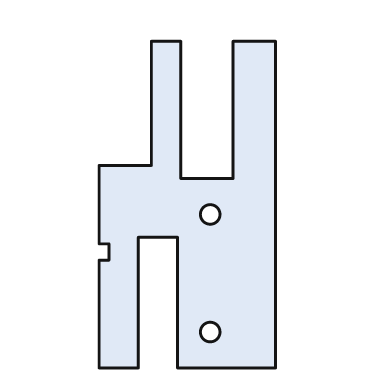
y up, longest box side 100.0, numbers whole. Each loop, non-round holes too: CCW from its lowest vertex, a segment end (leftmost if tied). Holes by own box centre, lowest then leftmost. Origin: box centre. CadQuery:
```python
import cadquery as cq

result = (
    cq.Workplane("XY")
    .moveTo(-27.0, -50.0)
    .lineTo(-15.0, -50.0)
    .lineTo(-15.0, -10.0)
    .lineTo(-3.0, -10.0)
    .lineTo(-3.0, -50.0)
    .lineTo(27.0, -50.0)
    .lineTo(27.0, 50.0)
    .lineTo(14.0, 50.0)
    .lineTo(14.0, 8.0)
    .lineTo(-2.0, 8.0)
    .lineTo(-2.0, 50.0)
    .lineTo(-11.0, 50.0)
    .lineTo(-11.0, 12.0)
    .lineTo(-27.0, 12.0)
    .lineTo(-27.0, -12.0)
    .lineTo(-24.0, -12.0)
    .lineTo(-24.0, -17.0)
    .lineTo(-27.0, -17.0)
    .close()
    .moveTo(7.0, -39.0)
    .circle(3.0)
    .moveTo(7.0, -3.0)
    .circle(3.0)
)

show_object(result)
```